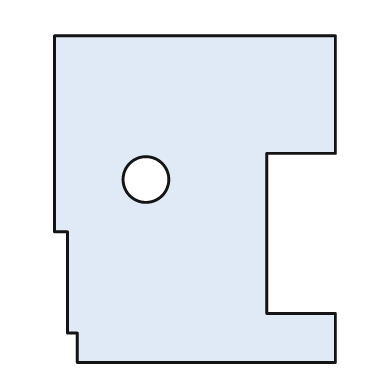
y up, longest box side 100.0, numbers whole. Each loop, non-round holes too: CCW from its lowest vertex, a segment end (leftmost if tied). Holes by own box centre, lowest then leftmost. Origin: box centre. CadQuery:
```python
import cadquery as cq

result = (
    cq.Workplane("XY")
    .moveTo(-36.0, -50.0)
    .lineTo(43.0, -50.0)
    .lineTo(43.0, -35.0)
    .lineTo(22.0, -35.0)
    .lineTo(22.0, 14.0)
    .lineTo(43.0, 14.0)
    .lineTo(43.0, 50.0)
    .lineTo(-43.0, 50.0)
    .lineTo(-43.0, -10.0)
    .lineTo(-39.0, -10.0)
    .lineTo(-39.0, -41.0)
    .lineTo(-36.0, -41.0)
    .close()
    .moveTo(-15.0, 6.0)
    .circle(7.0)
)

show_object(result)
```